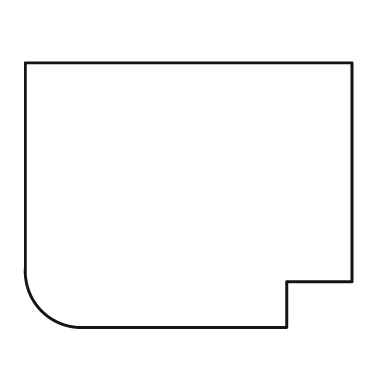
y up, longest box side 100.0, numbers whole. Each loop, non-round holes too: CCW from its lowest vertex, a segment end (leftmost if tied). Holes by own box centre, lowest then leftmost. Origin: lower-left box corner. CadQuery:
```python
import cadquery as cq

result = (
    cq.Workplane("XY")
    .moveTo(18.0, 0.0)
    .lineTo(80.0, 0.0)
    .lineTo(80.0, 14.0)
    .lineTo(100.0, 14.0)
    .lineTo(100.0, 81.0)
    .lineTo(0.0, 81.0)
    .lineTo(0.0, 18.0)
    .threePointArc((5.0, 5.0), (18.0, 0.0))
    .close()
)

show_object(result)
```